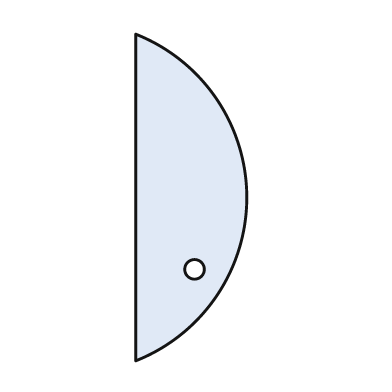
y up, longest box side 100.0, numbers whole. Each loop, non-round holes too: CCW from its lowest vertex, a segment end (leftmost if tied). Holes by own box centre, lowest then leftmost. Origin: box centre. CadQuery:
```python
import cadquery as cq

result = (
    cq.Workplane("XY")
    .moveTo(-17.0, -50.0)
    .threePointArc((17.0, 0.0), (-17.0, 50.0))
    .close()
    .moveTo(1.0, -22.0)
    .circle(3.0)
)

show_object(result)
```